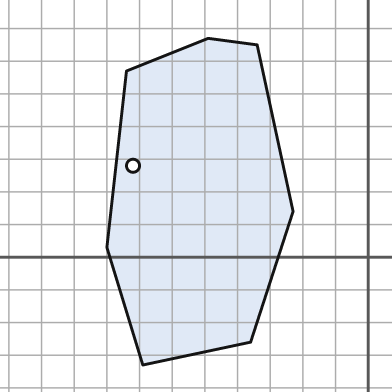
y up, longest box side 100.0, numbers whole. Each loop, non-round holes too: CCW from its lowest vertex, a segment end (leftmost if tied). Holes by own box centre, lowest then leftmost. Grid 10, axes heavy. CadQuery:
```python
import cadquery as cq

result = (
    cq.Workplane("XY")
    .moveTo(-69.0, -33.0)
    .lineTo(-36.0, -26.0)
    .lineTo(-23.0, 14.0)
    .lineTo(-34.0, 65.0)
    .lineTo(-49.0, 67.0)
    .lineTo(-74.0, 57.0)
    .lineTo(-80.0, 3.0)
    .close()
    .moveTo(-72.0, 28.0)
    .circle(2.0)
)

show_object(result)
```